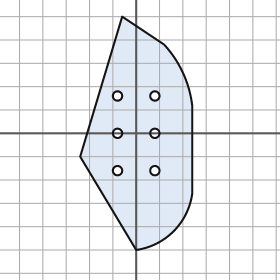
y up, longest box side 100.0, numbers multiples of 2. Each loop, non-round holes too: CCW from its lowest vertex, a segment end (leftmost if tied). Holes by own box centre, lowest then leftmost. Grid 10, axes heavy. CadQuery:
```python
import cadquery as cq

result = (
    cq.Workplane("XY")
    .moveTo(0.0, -50.0)
    .threePointArc((16.0, -42.0), (24.0, -26.0))
    .lineTo(24.0, 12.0)
    .threePointArc((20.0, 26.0), (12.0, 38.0))
    .lineTo(-6.0, 50.0)
    .lineTo(-24.0, -10.0)
    .close()
    .moveTo(-8.0, -16.0)
    .circle(2.0)
    .moveTo(8.0, -16.0)
    .circle(2.0)
    .moveTo(-8.0, 0.0)
    .circle(2.0)
    .moveTo(8.0, 0.0)
    .circle(2.0)
    .moveTo(-8.0, 16.0)
    .circle(2.0)
    .moveTo(8.0, 16.0)
    .circle(2.0)
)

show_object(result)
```